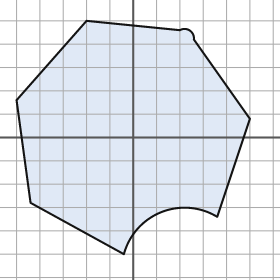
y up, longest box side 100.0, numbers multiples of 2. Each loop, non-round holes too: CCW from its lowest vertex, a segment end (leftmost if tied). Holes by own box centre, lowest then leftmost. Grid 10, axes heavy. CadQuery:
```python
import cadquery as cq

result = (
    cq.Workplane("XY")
    .moveTo(-4.0, -50.0)
    .threePointArc((12.0, -32.0), (36.0, -34.0))
    .lineTo(50.0, 8.0)
    .lineTo(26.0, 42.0)
    .threePointArc((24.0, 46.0), (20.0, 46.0))
    .lineTo(-20.0, 50.0)
    .lineTo(-50.0, 16.0)
    .lineTo(-44.0, -28.0)
    .close()
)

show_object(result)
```